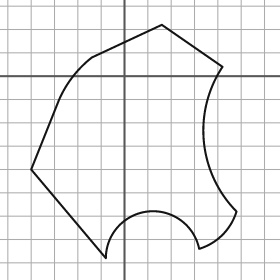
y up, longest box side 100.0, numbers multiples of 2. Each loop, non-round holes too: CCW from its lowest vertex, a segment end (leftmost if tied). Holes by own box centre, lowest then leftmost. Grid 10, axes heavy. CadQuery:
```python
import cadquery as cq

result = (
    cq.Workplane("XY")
    .moveTo(-8.0, -78.0)
    .threePointArc((10.0, -58.0), (32.0, -74.0))
    .threePointArc((42.0, -68.0), (48.0, -58.0))
    .threePointArc((34.0, -28.0), (42.0, 4.0))
    .lineTo(16.0, 22.0)
    .lineTo(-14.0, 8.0)
    .threePointArc((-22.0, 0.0), (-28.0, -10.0))
    .lineTo(-40.0, -40.0)
    .close()
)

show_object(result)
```